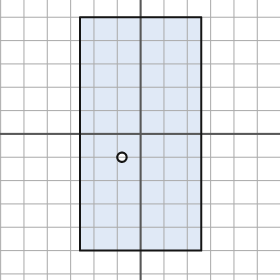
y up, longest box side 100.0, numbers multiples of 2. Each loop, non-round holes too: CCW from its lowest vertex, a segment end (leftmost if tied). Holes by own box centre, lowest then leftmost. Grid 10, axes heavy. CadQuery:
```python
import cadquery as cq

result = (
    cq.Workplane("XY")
    .moveTo(-26.0, -50.0)
    .lineTo(26.0, -50.0)
    .lineTo(26.0, 50.0)
    .lineTo(-26.0, 50.0)
    .close()
    .moveTo(-8.0, -10.0)
    .circle(2.0)
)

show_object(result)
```